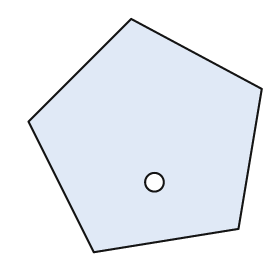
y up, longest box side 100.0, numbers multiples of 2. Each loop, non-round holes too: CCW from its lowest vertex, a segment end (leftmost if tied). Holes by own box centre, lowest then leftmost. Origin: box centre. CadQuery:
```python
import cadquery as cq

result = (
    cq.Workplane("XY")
    .moveTo(-22.0, -50.0)
    .lineTo(40.0, -40.0)
    .lineTo(50.0, 20.0)
    .lineTo(-6.0, 50.0)
    .lineTo(-50.0, 6.0)
    .close()
    .moveTo(4.0, -20.0)
    .circle(4.0)
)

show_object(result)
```